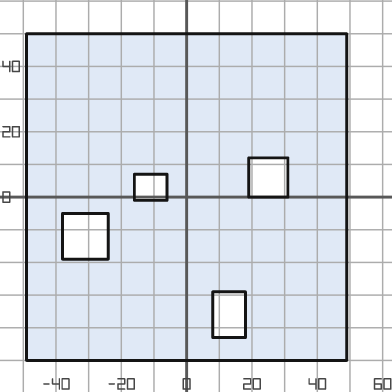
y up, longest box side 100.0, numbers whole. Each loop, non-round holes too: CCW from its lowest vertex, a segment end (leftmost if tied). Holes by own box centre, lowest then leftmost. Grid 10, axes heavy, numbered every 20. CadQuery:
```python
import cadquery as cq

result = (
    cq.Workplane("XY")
    .moveTo(-49.0, -50.0)
    .lineTo(49.0, -50.0)
    .lineTo(49.0, 50.0)
    .lineTo(-49.0, 50.0)
    .close()
    .moveTo(8.0, -43.0)
    .lineTo(18.0, -43.0)
    .lineTo(18.0, -29.0)
    .lineTo(8.0, -29.0)
    .close()
    .moveTo(-38.0, -19.0)
    .lineTo(-24.0, -19.0)
    .lineTo(-24.0, -5.0)
    .lineTo(-38.0, -5.0)
    .close()
    .moveTo(-16.0, -1.0)
    .lineTo(-6.0, -1.0)
    .lineTo(-6.0, 7.0)
    .lineTo(-16.0, 7.0)
    .close()
    .moveTo(19.0, 0.0)
    .lineTo(31.0, 0.0)
    .lineTo(31.0, 12.0)
    .lineTo(19.0, 12.0)
    .close()
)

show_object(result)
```